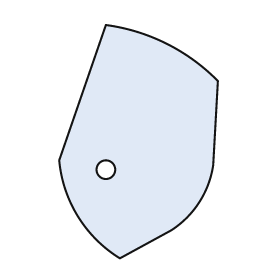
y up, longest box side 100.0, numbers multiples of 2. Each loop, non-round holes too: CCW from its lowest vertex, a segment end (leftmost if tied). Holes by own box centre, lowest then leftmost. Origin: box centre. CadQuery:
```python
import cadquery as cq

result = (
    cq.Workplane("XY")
    .moveTo(-8.0, -50.0)
    .lineTo(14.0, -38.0)
    .threePointArc((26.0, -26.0), (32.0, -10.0))
    .lineTo(34.0, 26.0)
    .threePointArc((12.0, 42.0), (-14.0, 50.0))
    .lineTo(-34.0, -8.0)
    .threePointArc((-26.0, -32.0), (-8.0, -50.0))
    .close()
    .moveTo(-14.0, -12.0)
    .circle(4.0)
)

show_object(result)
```